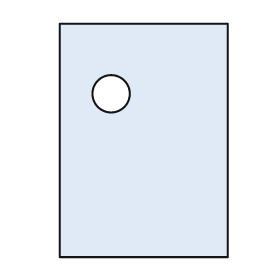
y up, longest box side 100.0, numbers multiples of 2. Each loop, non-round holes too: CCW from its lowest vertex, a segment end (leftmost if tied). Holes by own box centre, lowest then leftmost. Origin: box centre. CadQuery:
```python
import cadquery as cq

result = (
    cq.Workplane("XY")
    .moveTo(-36.0, -50.0)
    .lineTo(36.0, -50.0)
    .lineTo(36.0, 50.0)
    .lineTo(-36.0, 50.0)
    .close()
    .moveTo(-14.0, 20.0)
    .circle(8.0)
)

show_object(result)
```